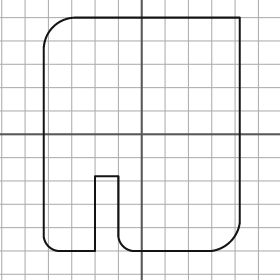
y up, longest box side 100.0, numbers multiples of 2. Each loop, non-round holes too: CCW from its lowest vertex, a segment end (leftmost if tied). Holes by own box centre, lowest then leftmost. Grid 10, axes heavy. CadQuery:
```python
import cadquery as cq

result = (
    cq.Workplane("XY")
    .moveTo(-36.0, -50.0)
    .lineTo(-20.0, -50.0)
    .lineTo(-20.0, -18.0)
    .lineTo(-10.0, -18.0)
    .lineTo(-10.0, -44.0)
    .threePointArc((-8.0, -48.0), (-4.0, -50.0))
    .lineTo(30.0, -50.0)
    .threePointArc((38.0, -46.0), (42.0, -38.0))
    .lineTo(42.0, 50.0)
    .lineTo(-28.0, 50.0)
    .threePointArc((-38.0, 46.0), (-42.0, 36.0))
    .lineTo(-42.0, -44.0)
    .threePointArc((-40.0, -48.0), (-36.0, -50.0))
    .close()
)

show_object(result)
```